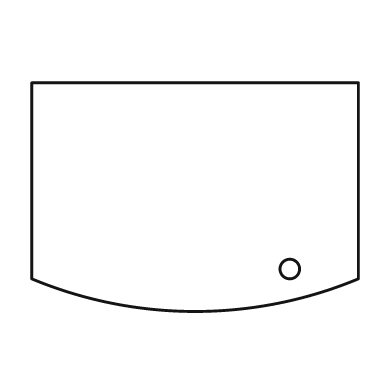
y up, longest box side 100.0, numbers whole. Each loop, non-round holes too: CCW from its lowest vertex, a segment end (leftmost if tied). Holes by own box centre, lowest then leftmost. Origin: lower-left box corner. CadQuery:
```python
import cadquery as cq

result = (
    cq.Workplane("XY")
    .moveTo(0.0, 10.0)
    .threePointArc((50.0, 0.0), (100.0, 10.0))
    .lineTo(100.0, 70.0)
    .lineTo(0.0, 70.0)
    .close()
    .moveTo(79.0, 13.0)
    .circle(3.0)
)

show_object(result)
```